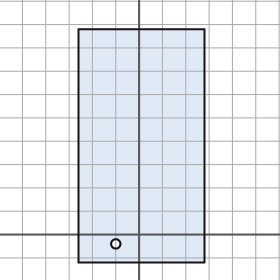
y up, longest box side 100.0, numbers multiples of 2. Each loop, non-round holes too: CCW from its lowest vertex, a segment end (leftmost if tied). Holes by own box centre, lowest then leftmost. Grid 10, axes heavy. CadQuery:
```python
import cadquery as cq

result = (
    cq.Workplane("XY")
    .moveTo(-26.0, -12.0)
    .lineTo(28.0, -12.0)
    .lineTo(28.0, 88.0)
    .lineTo(-26.0, 88.0)
    .close()
    .moveTo(-10.0, -4.0)
    .circle(2.0)
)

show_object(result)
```